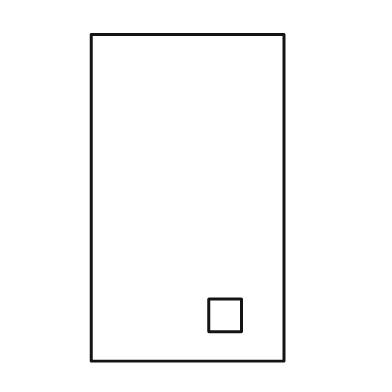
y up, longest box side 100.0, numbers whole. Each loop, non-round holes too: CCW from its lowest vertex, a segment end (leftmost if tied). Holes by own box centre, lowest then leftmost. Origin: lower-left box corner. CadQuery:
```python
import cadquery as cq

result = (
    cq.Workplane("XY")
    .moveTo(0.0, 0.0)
    .lineTo(59.0, 0.0)
    .lineTo(59.0, 100.0)
    .lineTo(0.0, 100.0)
    .close()
    .moveTo(36.0, 9.0)
    .lineTo(46.0, 9.0)
    .lineTo(46.0, 19.0)
    .lineTo(36.0, 19.0)
    .close()
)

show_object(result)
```